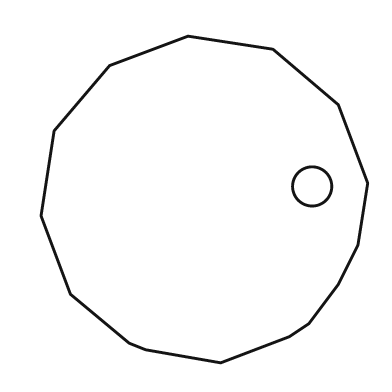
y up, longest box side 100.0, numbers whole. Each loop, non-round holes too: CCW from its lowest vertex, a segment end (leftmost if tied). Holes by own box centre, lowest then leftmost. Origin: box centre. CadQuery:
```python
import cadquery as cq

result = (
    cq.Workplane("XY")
    .moveTo(5.0, -50.0)
    .lineTo(26.0, -42.0)
    .lineTo(32.0, -38.0)
    .lineTo(41.0, -26.0)
    .lineTo(47.0, -14.0)
    .lineTo(50.0, 5.0)
    .lineTo(41.0, 29.0)
    .lineTo(21.0, 46.0)
    .lineTo(-5.0, 50.0)
    .lineTo(-29.0, 41.0)
    .lineTo(-46.0, 21.0)
    .lineTo(-50.0, -5.0)
    .lineTo(-41.0, -29.0)
    .lineTo(-23.0, -44.0)
    .lineTo(-18.0, -46.0)
    .close()
    .moveTo(33.0, 4.0)
    .circle(6.0)
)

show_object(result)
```